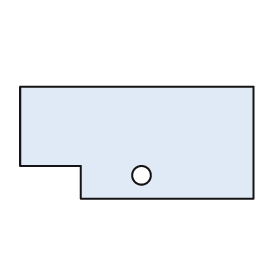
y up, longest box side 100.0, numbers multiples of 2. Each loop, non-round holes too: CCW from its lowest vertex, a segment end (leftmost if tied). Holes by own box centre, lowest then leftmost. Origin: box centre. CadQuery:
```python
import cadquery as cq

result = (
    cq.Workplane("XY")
    .moveTo(-24.0, -24.0)
    .lineTo(50.0, -24.0)
    .lineTo(50.0, 24.0)
    .lineTo(-50.0, 24.0)
    .lineTo(-50.0, -10.0)
    .lineTo(-24.0, -10.0)
    .close()
    .moveTo(2.0, -14.0)
    .circle(4.0)
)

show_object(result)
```